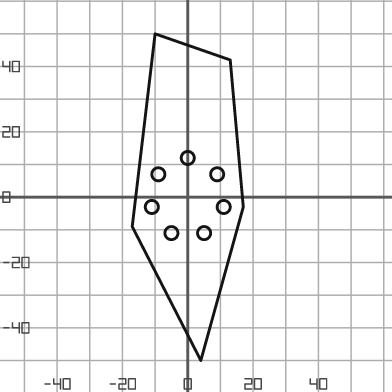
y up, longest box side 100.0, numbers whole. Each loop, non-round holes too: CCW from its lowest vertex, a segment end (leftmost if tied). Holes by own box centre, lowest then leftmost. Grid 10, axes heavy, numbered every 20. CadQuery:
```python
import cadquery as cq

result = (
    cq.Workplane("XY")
    .moveTo(4.0, -50.0)
    .lineTo(17.0, -3.0)
    .lineTo(13.0, 42.0)
    .lineTo(-10.0, 50.0)
    .lineTo(-17.0, -9.0)
    .close()
    .moveTo(-5.0, -11.0)
    .circle(2.0)
    .moveTo(5.0, -11.0)
    .circle(2.0)
    .moveTo(-11.0, -3.0)
    .circle(2.0)
    .moveTo(11.0, -3.0)
    .circle(2.0)
    .moveTo(-9.0, 7.0)
    .circle(2.0)
    .moveTo(9.0, 7.0)
    .circle(2.0)
    .moveTo(0.0, 12.0)
    .circle(2.0)
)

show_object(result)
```